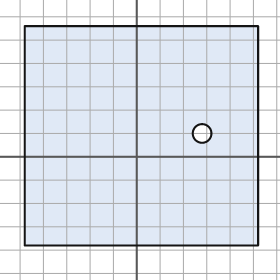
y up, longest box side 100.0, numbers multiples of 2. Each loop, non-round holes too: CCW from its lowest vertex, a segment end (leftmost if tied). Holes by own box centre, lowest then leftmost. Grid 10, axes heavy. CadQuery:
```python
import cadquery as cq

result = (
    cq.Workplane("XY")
    .moveTo(-48.0, -38.0)
    .lineTo(52.0, -38.0)
    .lineTo(52.0, 56.0)
    .lineTo(-48.0, 56.0)
    .close()
    .moveTo(28.0, 10.0)
    .circle(4.0)
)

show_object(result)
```